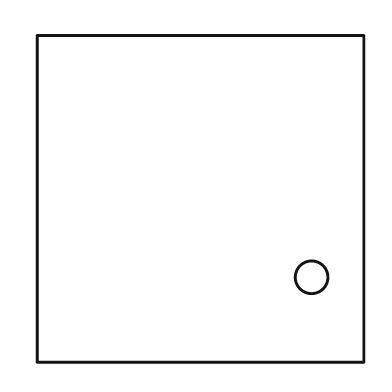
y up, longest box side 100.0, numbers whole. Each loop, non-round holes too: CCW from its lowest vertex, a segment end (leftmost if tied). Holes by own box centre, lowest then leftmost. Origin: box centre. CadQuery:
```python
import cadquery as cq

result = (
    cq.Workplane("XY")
    .moveTo(-50.0, -50.0)
    .lineTo(50.0, -50.0)
    .lineTo(50.0, 50.0)
    .lineTo(-50.0, 50.0)
    .close()
    .moveTo(34.0, -24.0)
    .circle(5.0)
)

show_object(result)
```